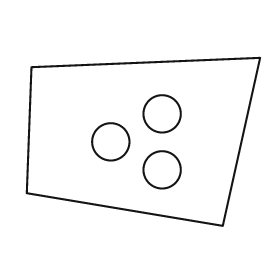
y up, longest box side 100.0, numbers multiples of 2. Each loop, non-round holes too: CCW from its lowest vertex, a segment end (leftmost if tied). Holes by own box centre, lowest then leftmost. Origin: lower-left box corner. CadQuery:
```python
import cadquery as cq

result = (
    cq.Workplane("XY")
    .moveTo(84.0, 0.0)
    .lineTo(100.0, 72.0)
    .lineTo(2.0, 68.0)
    .lineTo(0.0, 14.0)
    .close()
    .moveTo(58.0, 24.0)
    .circle(8.0)
    .moveTo(36.0, 36.0)
    .circle(8.0)
    .moveTo(58.0, 48.0)
    .circle(8.0)
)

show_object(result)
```